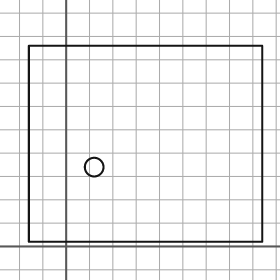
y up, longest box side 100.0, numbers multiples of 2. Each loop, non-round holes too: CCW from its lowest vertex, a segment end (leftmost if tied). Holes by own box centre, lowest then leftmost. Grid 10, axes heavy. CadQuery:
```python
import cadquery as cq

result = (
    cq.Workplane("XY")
    .moveTo(-16.0, 2.0)
    .lineTo(84.0, 2.0)
    .lineTo(84.0, 86.0)
    .lineTo(-16.0, 86.0)
    .close()
    .moveTo(12.0, 34.0)
    .circle(4.0)
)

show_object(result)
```